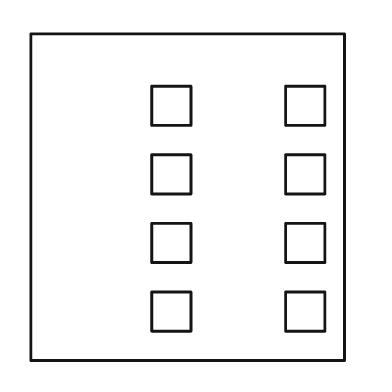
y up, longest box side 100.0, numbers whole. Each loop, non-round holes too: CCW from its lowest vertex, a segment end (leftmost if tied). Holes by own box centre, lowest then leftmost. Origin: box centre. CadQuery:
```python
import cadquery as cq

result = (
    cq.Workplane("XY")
    .moveTo(-48.0, -50.0)
    .lineTo(48.0, -50.0)
    .lineTo(48.0, 50.0)
    .lineTo(-48.0, 50.0)
    .close()
    .moveTo(-11.0, -41.0)
    .lineTo(1.0, -41.0)
    .lineTo(1.0, -29.0)
    .lineTo(-11.0, -29.0)
    .close()
    .moveTo(30.0, -41.0)
    .lineTo(42.0, -41.0)
    .lineTo(42.0, -29.0)
    .lineTo(30.0, -29.0)
    .close()
    .moveTo(-11.0, -20.0)
    .lineTo(1.0, -20.0)
    .lineTo(1.0, -8.0)
    .lineTo(-11.0, -8.0)
    .close()
    .moveTo(30.0, -20.0)
    .lineTo(42.0, -20.0)
    .lineTo(42.0, -8.0)
    .lineTo(30.0, -8.0)
    .close()
    .moveTo(-11.0, 1.0)
    .lineTo(1.0, 1.0)
    .lineTo(1.0, 13.0)
    .lineTo(-11.0, 13.0)
    .close()
    .moveTo(30.0, 1.0)
    .lineTo(42.0, 1.0)
    .lineTo(42.0, 13.0)
    .lineTo(30.0, 13.0)
    .close()
    .moveTo(-11.0, 22.0)
    .lineTo(1.0, 22.0)
    .lineTo(1.0, 34.0)
    .lineTo(-11.0, 34.0)
    .close()
    .moveTo(30.0, 22.0)
    .lineTo(42.0, 22.0)
    .lineTo(42.0, 34.0)
    .lineTo(30.0, 34.0)
    .close()
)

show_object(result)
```